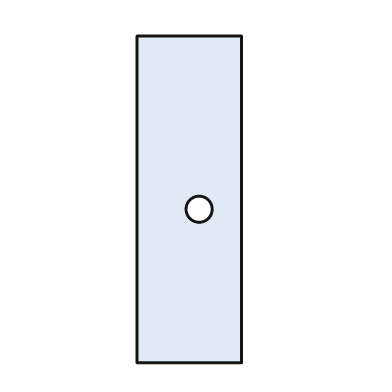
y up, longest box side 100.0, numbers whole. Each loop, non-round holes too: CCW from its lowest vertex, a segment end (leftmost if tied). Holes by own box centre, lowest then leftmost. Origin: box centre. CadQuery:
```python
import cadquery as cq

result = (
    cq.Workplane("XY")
    .moveTo(-16.0, -50.0)
    .lineTo(16.0, -50.0)
    .lineTo(16.0, 50.0)
    .lineTo(-16.0, 50.0)
    .close()
    .moveTo(3.0, -3.0)
    .circle(4.0)
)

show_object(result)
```